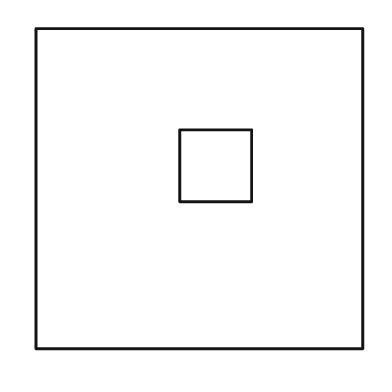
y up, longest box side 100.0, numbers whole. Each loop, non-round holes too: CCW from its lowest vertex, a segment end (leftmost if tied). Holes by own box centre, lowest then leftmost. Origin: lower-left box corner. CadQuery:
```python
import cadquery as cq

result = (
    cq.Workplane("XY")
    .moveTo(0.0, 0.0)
    .lineTo(100.0, 0.0)
    .lineTo(100.0, 98.0)
    .lineTo(0.0, 98.0)
    .close()
    .moveTo(44.0, 45.0)
    .lineTo(66.0, 45.0)
    .lineTo(66.0, 67.0)
    .lineTo(44.0, 67.0)
    .close()
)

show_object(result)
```